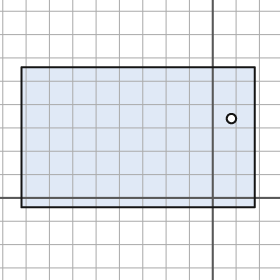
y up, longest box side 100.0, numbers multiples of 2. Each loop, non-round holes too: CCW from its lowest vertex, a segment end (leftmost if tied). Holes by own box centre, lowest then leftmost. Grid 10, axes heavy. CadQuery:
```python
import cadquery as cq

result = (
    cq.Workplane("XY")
    .moveTo(-82.0, -4.0)
    .lineTo(18.0, -4.0)
    .lineTo(18.0, 56.0)
    .lineTo(-82.0, 56.0)
    .close()
    .moveTo(8.0, 34.0)
    .circle(2.0)
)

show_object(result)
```